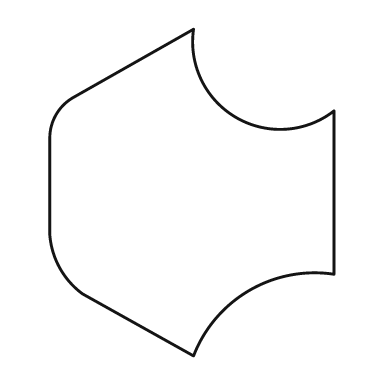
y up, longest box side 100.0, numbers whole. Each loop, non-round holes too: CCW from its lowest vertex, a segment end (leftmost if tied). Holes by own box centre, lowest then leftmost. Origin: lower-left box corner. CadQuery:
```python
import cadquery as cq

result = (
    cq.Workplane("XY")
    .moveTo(44.0, 0.0)
    .threePointArc((61.0, 20.0), (87.0, 25.0))
    .lineTo(87.0, 75.0)
    .threePointArc((57.0, 73.0), (44.0, 100.0))
    .lineTo(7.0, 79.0)
    .threePointArc((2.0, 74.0), (0.0, 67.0))
    .lineTo(0.0, 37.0)
    .threePointArc((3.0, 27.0), (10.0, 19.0))
    .close()
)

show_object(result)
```